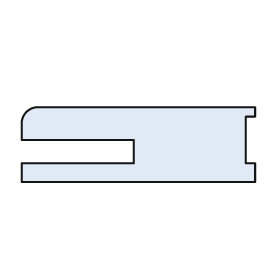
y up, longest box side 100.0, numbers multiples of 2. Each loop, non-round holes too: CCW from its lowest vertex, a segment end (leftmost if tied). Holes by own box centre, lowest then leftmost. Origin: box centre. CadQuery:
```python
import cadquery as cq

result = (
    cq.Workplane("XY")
    .moveTo(-50.0, -16.0)
    .lineTo(50.0, -16.0)
    .lineTo(50.0, -8.0)
    .lineTo(46.0, -8.0)
    .lineTo(46.0, 12.0)
    .lineTo(50.0, 12.0)
    .lineTo(50.0, 16.0)
    .lineTo(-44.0, 16.0)
    .threePointArc((-48.0, 14.0), (-50.0, 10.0))
    .lineTo(-50.0, 2.0)
    .lineTo(-2.0, 2.0)
    .lineTo(-2.0, -8.0)
    .lineTo(-50.0, -8.0)
    .close()
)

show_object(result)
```